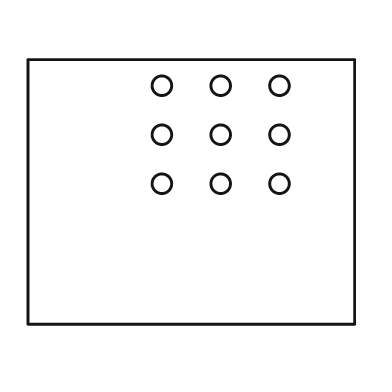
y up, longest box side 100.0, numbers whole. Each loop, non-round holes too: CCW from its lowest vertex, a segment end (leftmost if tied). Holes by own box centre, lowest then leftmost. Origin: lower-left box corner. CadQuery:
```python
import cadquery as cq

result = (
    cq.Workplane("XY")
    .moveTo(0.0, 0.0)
    .lineTo(100.0, 0.0)
    .lineTo(100.0, 81.0)
    .lineTo(0.0, 81.0)
    .close()
    .moveTo(41.0, 43.0)
    .circle(3.0)
    .moveTo(59.0, 43.0)
    .circle(3.0)
    .moveTo(77.0, 43.0)
    .circle(3.0)
    .moveTo(41.0, 58.0)
    .circle(3.0)
    .moveTo(59.0, 58.0)
    .circle(3.0)
    .moveTo(77.0, 58.0)
    .circle(3.0)
    .moveTo(41.0, 73.0)
    .circle(3.0)
    .moveTo(59.0, 73.0)
    .circle(3.0)
    .moveTo(77.0, 73.0)
    .circle(3.0)
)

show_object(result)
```